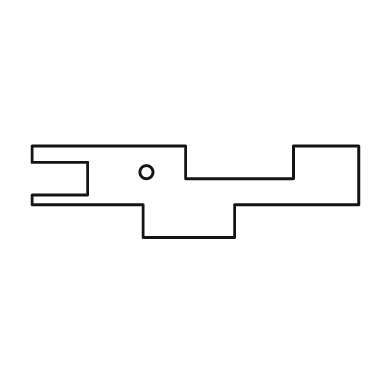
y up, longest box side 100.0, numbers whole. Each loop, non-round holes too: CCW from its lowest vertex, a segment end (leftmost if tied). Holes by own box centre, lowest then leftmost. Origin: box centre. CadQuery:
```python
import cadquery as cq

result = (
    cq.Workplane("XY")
    .moveTo(-16.0, -14.0)
    .lineTo(12.0, -14.0)
    .lineTo(12.0, -4.0)
    .lineTo(50.0, -4.0)
    .lineTo(50.0, 14.0)
    .lineTo(30.0, 14.0)
    .lineTo(30.0, 4.0)
    .lineTo(-3.0, 4.0)
    .lineTo(-3.0, 14.0)
    .lineTo(-50.0, 14.0)
    .lineTo(-50.0, 9.0)
    .lineTo(-33.0, 9.0)
    .lineTo(-33.0, -1.0)
    .lineTo(-50.0, -1.0)
    .lineTo(-50.0, -4.0)
    .lineTo(-16.0, -4.0)
    .close()
    .moveTo(-15.0, 6.0)
    .circle(2.0)
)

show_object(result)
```